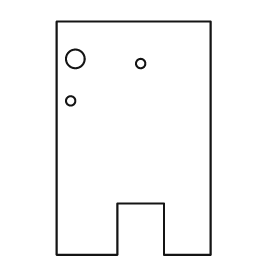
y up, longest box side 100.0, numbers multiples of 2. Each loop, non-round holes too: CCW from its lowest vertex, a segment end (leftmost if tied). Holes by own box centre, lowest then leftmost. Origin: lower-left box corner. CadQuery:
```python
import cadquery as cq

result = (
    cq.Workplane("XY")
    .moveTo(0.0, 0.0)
    .lineTo(26.0, 0.0)
    .lineTo(26.0, 22.0)
    .lineTo(46.0, 22.0)
    .lineTo(46.0, 0.0)
    .lineTo(66.0, 0.0)
    .lineTo(66.0, 100.0)
    .lineTo(0.0, 100.0)
    .close()
    .moveTo(6.0, 66.0)
    .circle(2.0)
    .moveTo(36.0, 82.0)
    .circle(2.0)
    .moveTo(8.0, 84.0)
    .circle(4.0)
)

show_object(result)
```